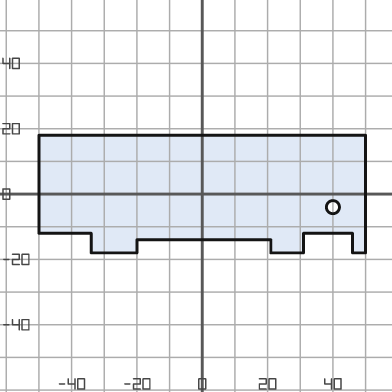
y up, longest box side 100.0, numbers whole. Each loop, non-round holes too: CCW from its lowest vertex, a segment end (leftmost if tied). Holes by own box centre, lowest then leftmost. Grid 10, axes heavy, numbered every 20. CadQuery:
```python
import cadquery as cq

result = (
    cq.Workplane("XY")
    .moveTo(-34.0, -18.0)
    .lineTo(-20.0, -18.0)
    .lineTo(-20.0, -14.0)
    .lineTo(21.0, -14.0)
    .lineTo(21.0, -18.0)
    .lineTo(31.0, -18.0)
    .lineTo(31.0, -12.0)
    .lineTo(46.0, -12.0)
    .lineTo(46.0, -18.0)
    .lineTo(50.0, -18.0)
    .lineTo(50.0, 18.0)
    .lineTo(-50.0, 18.0)
    .lineTo(-50.0, -12.0)
    .lineTo(-34.0, -12.0)
    .close()
    .moveTo(40.0, -4.0)
    .circle(2.0)
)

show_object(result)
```